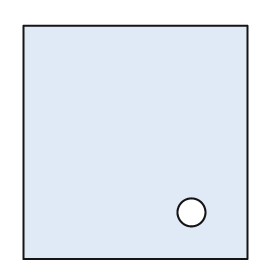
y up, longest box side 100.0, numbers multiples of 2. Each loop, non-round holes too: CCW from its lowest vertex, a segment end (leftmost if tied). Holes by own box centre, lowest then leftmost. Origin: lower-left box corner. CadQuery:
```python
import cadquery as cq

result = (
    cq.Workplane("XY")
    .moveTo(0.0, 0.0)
    .lineTo(96.0, 0.0)
    .lineTo(96.0, 100.0)
    .lineTo(0.0, 100.0)
    .close()
    .moveTo(72.0, 20.0)
    .circle(6.0)
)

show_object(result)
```